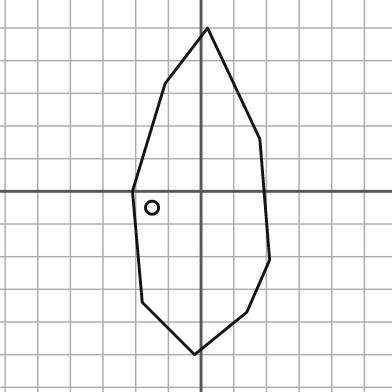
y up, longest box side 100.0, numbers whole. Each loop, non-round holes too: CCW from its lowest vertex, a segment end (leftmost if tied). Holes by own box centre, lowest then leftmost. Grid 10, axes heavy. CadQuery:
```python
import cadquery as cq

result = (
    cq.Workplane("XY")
    .moveTo(-2.0, -50.0)
    .lineTo(14.0, -37.0)
    .lineTo(21.0, -21.0)
    .lineTo(18.0, 16.0)
    .lineTo(2.0, 50.0)
    .lineTo(-11.0, 33.0)
    .lineTo(-21.0, 0.0)
    .lineTo(-18.0, -34.0)
    .close()
    .moveTo(-15.0, -5.0)
    .circle(2.0)
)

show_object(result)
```